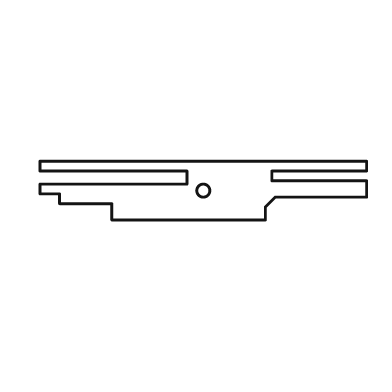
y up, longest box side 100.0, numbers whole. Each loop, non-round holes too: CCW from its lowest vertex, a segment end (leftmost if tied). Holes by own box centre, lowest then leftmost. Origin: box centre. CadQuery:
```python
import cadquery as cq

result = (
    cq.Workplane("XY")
    .moveTo(-28.0, -9.0)
    .lineTo(19.0, -9.0)
    .lineTo(19.0, -5.0)
    .lineTo(22.0, -2.0)
    .lineTo(50.0, -2.0)
    .lineTo(50.0, 3.0)
    .lineTo(21.0, 3.0)
    .lineTo(21.0, 6.0)
    .lineTo(50.0, 6.0)
    .lineTo(50.0, 9.0)
    .lineTo(-50.0, 9.0)
    .lineTo(-50.0, 6.0)
    .lineTo(-5.0, 6.0)
    .lineTo(-5.0, 2.0)
    .lineTo(-50.0, 2.0)
    .lineTo(-50.0, -1.0)
    .lineTo(-44.0, -1.0)
    .lineTo(-44.0, -4.0)
    .lineTo(-28.0, -4.0)
    .close()
    .moveTo(0.0, 0.0)
    .circle(2.0)
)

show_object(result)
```